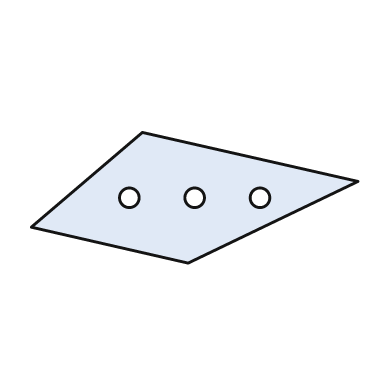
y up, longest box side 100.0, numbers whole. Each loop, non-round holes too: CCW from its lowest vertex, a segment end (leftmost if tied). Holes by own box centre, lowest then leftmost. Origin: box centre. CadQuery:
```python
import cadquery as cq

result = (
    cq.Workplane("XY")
    .moveTo(-2.0, -20.0)
    .lineTo(50.0, 5.0)
    .lineTo(-16.0, 20.0)
    .lineTo(-50.0, -9.0)
    .close()
    .moveTo(-20.0, 0.0)
    .circle(3.0)
    .moveTo(0.0, 0.0)
    .circle(3.0)
    .moveTo(20.0, 0.0)
    .circle(3.0)
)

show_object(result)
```